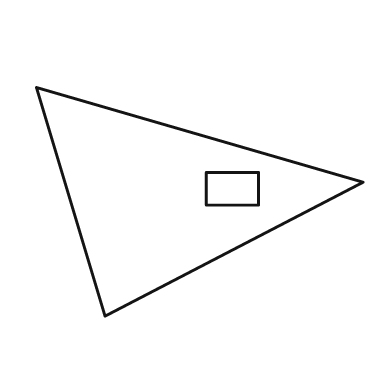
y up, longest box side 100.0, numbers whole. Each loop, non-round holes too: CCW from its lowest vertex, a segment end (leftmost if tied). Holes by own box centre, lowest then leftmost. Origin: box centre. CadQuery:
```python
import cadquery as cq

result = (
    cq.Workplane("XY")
    .moveTo(-29.0, -35.0)
    .lineTo(50.0, 6.0)
    .lineTo(-50.0, 35.0)
    .close()
    .moveTo(2.0, -1.0)
    .lineTo(18.0, -1.0)
    .lineTo(18.0, 9.0)
    .lineTo(2.0, 9.0)
    .close()
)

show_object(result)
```